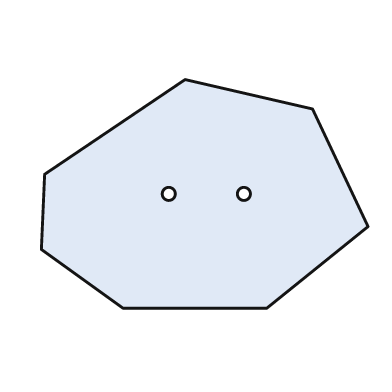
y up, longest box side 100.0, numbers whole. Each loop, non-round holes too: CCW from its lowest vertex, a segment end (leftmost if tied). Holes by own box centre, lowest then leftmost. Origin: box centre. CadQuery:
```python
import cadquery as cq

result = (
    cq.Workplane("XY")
    .moveTo(-25.0, -35.0)
    .lineTo(19.0, -35.0)
    .lineTo(50.0, -10.0)
    .lineTo(33.0, 26.0)
    .lineTo(-6.0, 35.0)
    .lineTo(-49.0, 6.0)
    .lineTo(-50.0, -17.0)
    .close()
    .moveTo(-11.0, 0.0)
    .circle(2.0)
    .moveTo(12.0, 0.0)
    .circle(2.0)
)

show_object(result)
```